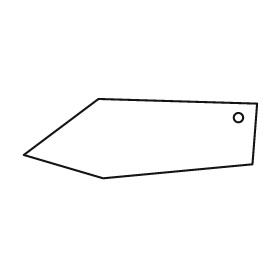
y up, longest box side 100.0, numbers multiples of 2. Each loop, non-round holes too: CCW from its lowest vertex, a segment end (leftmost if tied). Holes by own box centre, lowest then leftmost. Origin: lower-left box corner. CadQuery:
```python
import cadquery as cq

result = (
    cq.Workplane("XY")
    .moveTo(34.0, 0.0)
    .lineTo(98.0, 6.0)
    .lineTo(100.0, 32.0)
    .lineTo(32.0, 34.0)
    .lineTo(0.0, 10.0)
    .close()
    .moveTo(92.0, 26.0)
    .circle(2.0)
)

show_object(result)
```